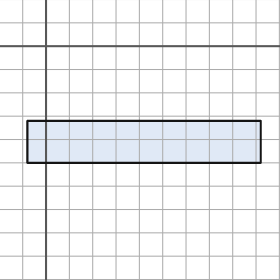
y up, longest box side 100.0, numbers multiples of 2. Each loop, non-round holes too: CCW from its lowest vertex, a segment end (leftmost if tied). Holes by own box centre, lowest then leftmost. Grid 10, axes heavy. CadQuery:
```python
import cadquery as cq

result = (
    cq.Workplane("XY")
    .moveTo(-8.0, -50.0)
    .lineTo(92.0, -50.0)
    .lineTo(92.0, -32.0)
    .lineTo(-8.0, -32.0)
    .close()
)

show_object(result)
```